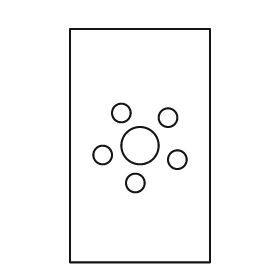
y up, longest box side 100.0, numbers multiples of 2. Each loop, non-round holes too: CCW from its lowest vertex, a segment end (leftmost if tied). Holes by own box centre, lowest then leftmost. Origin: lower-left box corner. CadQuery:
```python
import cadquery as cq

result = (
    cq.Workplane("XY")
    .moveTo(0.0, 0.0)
    .lineTo(60.0, 0.0)
    .lineTo(60.0, 100.0)
    .lineTo(0.0, 100.0)
    .close()
    .moveTo(28.0, 34.0)
    .circle(4.0)
    .moveTo(46.0, 44.0)
    .circle(4.0)
    .moveTo(14.0, 46.0)
    .circle(4.0)
    .moveTo(30.0, 50.0)
    .circle(8.0)
    .moveTo(42.0, 62.0)
    .circle(4.0)
    .moveTo(22.0, 64.0)
    .circle(4.0)
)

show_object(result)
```